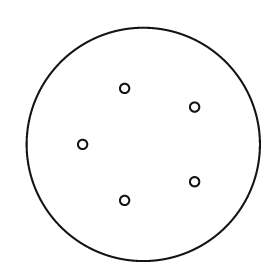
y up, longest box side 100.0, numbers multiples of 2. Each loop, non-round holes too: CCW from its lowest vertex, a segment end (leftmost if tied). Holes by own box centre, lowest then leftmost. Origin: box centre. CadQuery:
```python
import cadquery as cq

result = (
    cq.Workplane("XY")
    .moveTo(0.0, 0.0)
    .circle(50.0)
    .moveTo(-8.0, -24.0)
    .circle(2.0)
    .moveTo(22.0, -16.0)
    .circle(2.0)
    .moveTo(-26.0, 0.0)
    .circle(2.0)
    .moveTo(22.0, 16.0)
    .circle(2.0)
    .moveTo(-8.0, 24.0)
    .circle(2.0)
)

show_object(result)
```